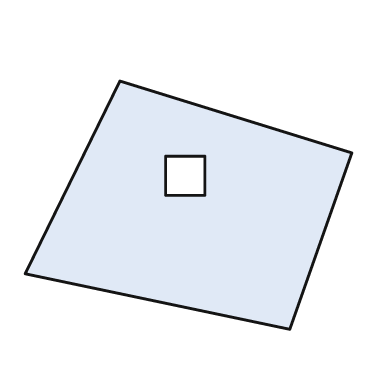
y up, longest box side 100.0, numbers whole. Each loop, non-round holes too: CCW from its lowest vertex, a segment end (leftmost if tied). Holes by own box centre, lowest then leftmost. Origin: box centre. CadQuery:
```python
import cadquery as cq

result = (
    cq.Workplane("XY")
    .moveTo(31.0, -38.0)
    .lineTo(50.0, 16.0)
    .lineTo(-21.0, 38.0)
    .lineTo(-50.0, -21.0)
    .close()
    .moveTo(-7.0, 3.0)
    .lineTo(5.0, 3.0)
    .lineTo(5.0, 15.0)
    .lineTo(-7.0, 15.0)
    .close()
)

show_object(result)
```